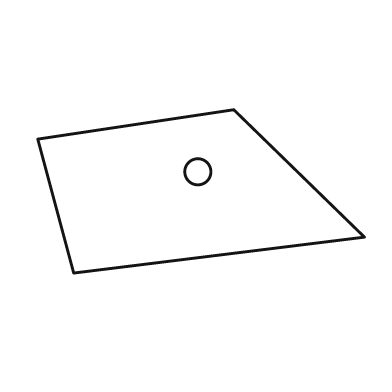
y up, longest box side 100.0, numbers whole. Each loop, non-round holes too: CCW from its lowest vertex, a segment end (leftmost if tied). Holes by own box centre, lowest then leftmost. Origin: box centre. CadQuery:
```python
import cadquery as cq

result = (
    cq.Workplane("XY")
    .moveTo(-39.0, -25.0)
    .lineTo(50.0, -14.0)
    .lineTo(10.0, 25.0)
    .lineTo(-50.0, 16.0)
    .close()
    .moveTo(-1.0, 6.0)
    .circle(4.0)
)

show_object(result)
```